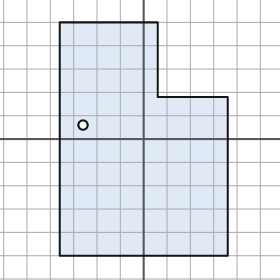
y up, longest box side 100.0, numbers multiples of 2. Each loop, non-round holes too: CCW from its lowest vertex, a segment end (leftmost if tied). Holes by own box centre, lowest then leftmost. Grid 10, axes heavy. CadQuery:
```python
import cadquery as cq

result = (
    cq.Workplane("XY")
    .moveTo(-36.0, -50.0)
    .lineTo(36.0, -50.0)
    .lineTo(36.0, 18.0)
    .lineTo(6.0, 18.0)
    .lineTo(6.0, 50.0)
    .lineTo(-36.0, 50.0)
    .close()
    .moveTo(-26.0, 6.0)
    .circle(2.0)
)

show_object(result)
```